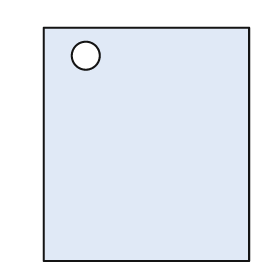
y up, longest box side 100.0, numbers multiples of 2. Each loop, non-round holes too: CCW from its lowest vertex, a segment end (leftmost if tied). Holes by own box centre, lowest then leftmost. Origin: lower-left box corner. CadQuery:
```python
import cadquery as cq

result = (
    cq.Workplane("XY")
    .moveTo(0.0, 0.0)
    .lineTo(88.0, 0.0)
    .lineTo(88.0, 100.0)
    .lineTo(0.0, 100.0)
    .close()
    .moveTo(18.0, 88.0)
    .circle(6.0)
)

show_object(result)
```